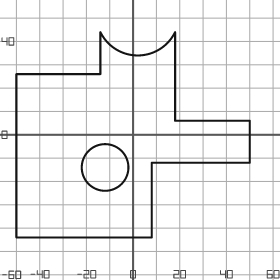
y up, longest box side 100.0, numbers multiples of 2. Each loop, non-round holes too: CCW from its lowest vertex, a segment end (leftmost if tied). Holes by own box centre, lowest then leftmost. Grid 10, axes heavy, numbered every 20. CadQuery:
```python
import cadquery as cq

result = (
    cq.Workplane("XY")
    .moveTo(-50.0, -44.0)
    .lineTo(8.0, -44.0)
    .lineTo(8.0, -12.0)
    .lineTo(50.0, -12.0)
    .lineTo(50.0, 6.0)
    .lineTo(18.0, 6.0)
    .lineTo(18.0, 44.0)
    .threePointArc((2.0, 34.0), (-14.0, 44.0))
    .lineTo(-14.0, 26.0)
    .lineTo(-50.0, 26.0)
    .close()
    .moveTo(-12.0, -14.0)
    .circle(10.0)
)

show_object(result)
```